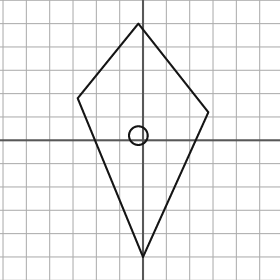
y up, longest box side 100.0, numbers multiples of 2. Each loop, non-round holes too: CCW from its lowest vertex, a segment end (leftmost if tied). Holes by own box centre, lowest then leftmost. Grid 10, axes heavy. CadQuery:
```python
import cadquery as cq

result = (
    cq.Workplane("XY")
    .moveTo(0.0, -50.0)
    .lineTo(28.0, 12.0)
    .lineTo(-2.0, 50.0)
    .lineTo(-28.0, 18.0)
    .close()
    .moveTo(-2.0, 2.0)
    .circle(4.0)
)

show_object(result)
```